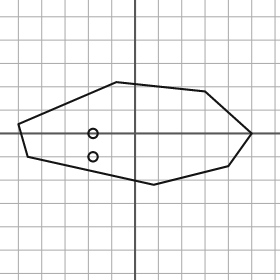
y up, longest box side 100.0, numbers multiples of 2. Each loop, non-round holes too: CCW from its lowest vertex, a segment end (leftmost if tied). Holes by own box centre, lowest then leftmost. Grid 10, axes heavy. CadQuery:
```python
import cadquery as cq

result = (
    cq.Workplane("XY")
    .moveTo(8.0, -22.0)
    .lineTo(40.0, -14.0)
    .lineTo(50.0, 0.0)
    .lineTo(30.0, 18.0)
    .lineTo(-8.0, 22.0)
    .lineTo(-50.0, 4.0)
    .lineTo(-46.0, -10.0)
    .close()
    .moveTo(-18.0, -10.0)
    .circle(2.0)
    .moveTo(-18.0, 0.0)
    .circle(2.0)
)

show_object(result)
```